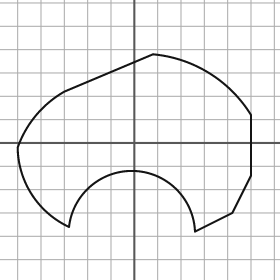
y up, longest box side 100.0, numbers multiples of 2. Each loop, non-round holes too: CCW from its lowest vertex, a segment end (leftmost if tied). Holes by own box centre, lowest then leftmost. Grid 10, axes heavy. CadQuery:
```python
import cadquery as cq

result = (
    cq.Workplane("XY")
    .moveTo(26.0, -38.0)
    .lineTo(42.0, -30.0)
    .lineTo(50.0, -14.0)
    .lineTo(50.0, 12.0)
    .threePointArc((32.0, 30.0), (8.0, 38.0))
    .lineTo(-30.0, 22.0)
    .threePointArc((-42.0, 12.0), (-50.0, -2.0))
    .threePointArc((-44.0, -22.0), (-28.0, -36.0))
    .threePointArc((0.0, -12.0), (26.0, -38.0))
    .close()
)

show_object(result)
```